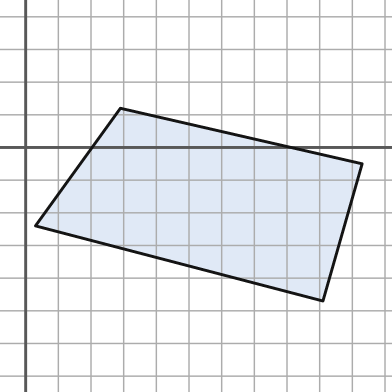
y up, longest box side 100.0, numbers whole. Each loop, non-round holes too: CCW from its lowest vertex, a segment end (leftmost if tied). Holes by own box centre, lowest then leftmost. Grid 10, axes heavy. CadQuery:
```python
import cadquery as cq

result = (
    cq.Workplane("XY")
    .moveTo(91.0, -47.0)
    .lineTo(103.0, -5.0)
    .lineTo(29.0, 12.0)
    .lineTo(3.0, -24.0)
    .close()
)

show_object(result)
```